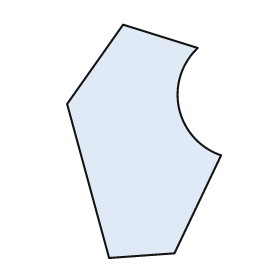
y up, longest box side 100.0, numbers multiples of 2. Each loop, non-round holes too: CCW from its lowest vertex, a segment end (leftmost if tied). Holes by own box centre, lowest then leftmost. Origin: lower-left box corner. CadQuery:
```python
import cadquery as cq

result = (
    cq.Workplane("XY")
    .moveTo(18.0, 0.0)
    .lineTo(46.0, 2.0)
    .lineTo(66.0, 44.0)
    .threePointArc((48.0, 64.0), (56.0, 90.0))
    .lineTo(24.0, 100.0)
    .lineTo(0.0, 66.0)
    .close()
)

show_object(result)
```